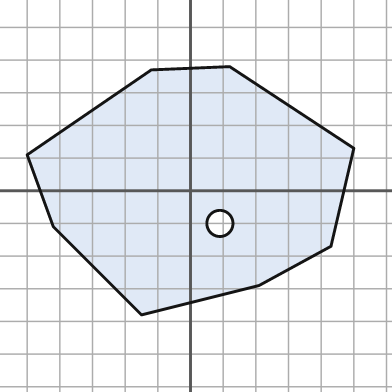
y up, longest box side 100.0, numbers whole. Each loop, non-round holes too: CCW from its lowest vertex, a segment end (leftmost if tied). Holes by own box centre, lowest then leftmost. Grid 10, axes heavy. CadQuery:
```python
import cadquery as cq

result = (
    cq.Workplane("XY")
    .moveTo(-15.0, -38.0)
    .lineTo(21.0, -29.0)
    .lineTo(43.0, -17.0)
    .lineTo(50.0, 13.0)
    .lineTo(12.0, 38.0)
    .lineTo(-12.0, 37.0)
    .lineTo(-50.0, 11.0)
    .lineTo(-42.0, -11.0)
    .close()
    .moveTo(9.0, -10.0)
    .circle(4.0)
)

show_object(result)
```